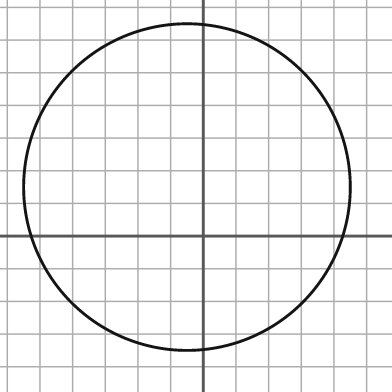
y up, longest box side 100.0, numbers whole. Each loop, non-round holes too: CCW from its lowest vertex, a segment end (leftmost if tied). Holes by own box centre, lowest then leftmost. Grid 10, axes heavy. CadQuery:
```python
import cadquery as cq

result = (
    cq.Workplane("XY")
    .moveTo(-5.0, 15.0)
    .circle(50.0)
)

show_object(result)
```